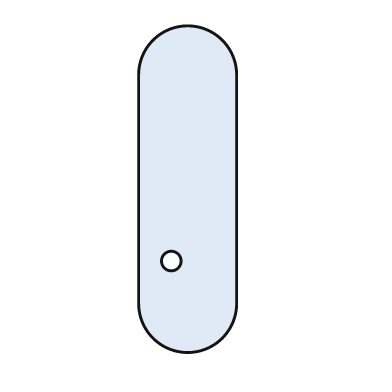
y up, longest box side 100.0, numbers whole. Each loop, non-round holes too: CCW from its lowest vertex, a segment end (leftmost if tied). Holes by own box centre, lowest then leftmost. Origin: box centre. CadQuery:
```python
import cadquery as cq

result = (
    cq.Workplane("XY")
    .moveTo(-15.0, -35.0)
    .threePointArc((0.0, -50.0), (15.0, -35.0))
    .lineTo(15.0, 35.0)
    .threePointArc((0.0, 50.0), (-15.0, 35.0))
    .close()
    .moveTo(-5.0, -22.0)
    .circle(3.0)
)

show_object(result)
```